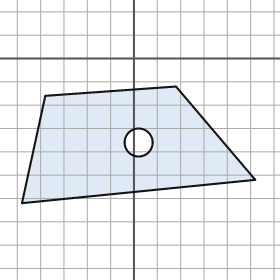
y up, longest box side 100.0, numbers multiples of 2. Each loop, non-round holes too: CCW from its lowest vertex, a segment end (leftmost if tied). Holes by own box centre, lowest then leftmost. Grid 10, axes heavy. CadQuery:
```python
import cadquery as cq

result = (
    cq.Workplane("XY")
    .moveTo(-48.0, -62.0)
    .lineTo(52.0, -52.0)
    .lineTo(18.0, -12.0)
    .lineTo(-38.0, -16.0)
    .close()
    .moveTo(2.0, -36.0)
    .circle(6.0)
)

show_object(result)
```